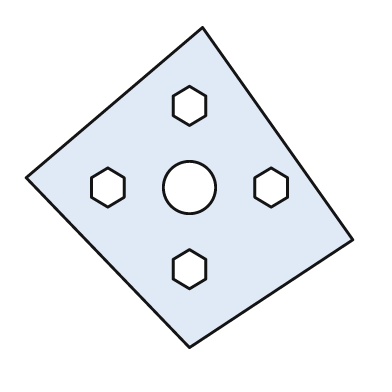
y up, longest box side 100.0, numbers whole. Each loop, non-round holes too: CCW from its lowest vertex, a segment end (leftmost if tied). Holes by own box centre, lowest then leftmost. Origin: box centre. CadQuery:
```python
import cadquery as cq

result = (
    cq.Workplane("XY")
    .moveTo(0.0, -49.0)
    .lineTo(50.0, -16.0)
    .lineTo(4.0, 49.0)
    .lineTo(-50.0, 3.0)
    .close()
    .moveTo(0.0, -31.0)
    .lineTo(5.0, -28.0)
    .lineTo(5.0, -22.0)
    .lineTo(0.0, -19.0)
    .lineTo(-5.0, -22.0)
    .lineTo(-5.0, -28.0)
    .close()
    .moveTo(-25.0, -6.0)
    .lineTo(-20.0, -3.0)
    .lineTo(-20.0, 3.0)
    .lineTo(-25.0, 6.0)
    .lineTo(-30.0, 3.0)
    .lineTo(-30.0, -3.0)
    .close()
    .moveTo(0.0, 0.0)
    .circle(8.0)
    .moveTo(25.0, -6.0)
    .lineTo(30.0, -3.0)
    .lineTo(30.0, 3.0)
    .lineTo(25.0, 6.0)
    .lineTo(20.0, 3.0)
    .lineTo(20.0, -3.0)
    .close()
    .moveTo(0.0, 19.0)
    .lineTo(5.0, 22.0)
    .lineTo(5.0, 28.0)
    .lineTo(0.0, 31.0)
    .lineTo(-5.0, 28.0)
    .lineTo(-5.0, 22.0)
    .close()
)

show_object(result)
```